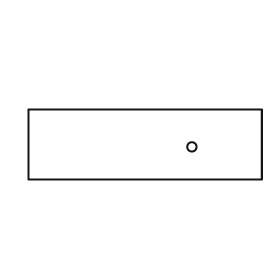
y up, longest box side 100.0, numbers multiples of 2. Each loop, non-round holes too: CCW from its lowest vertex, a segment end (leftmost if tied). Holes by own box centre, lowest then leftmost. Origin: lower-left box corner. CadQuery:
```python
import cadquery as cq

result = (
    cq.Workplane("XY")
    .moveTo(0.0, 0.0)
    .lineTo(100.0, 0.0)
    .lineTo(100.0, 30.0)
    .lineTo(0.0, 30.0)
    .close()
    .moveTo(70.0, 14.0)
    .circle(2.0)
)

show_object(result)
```